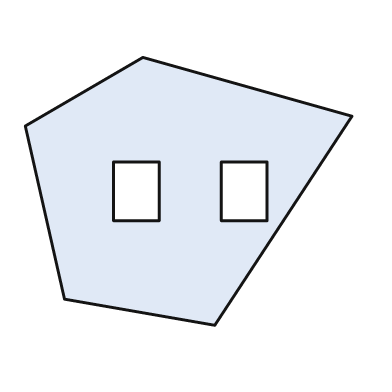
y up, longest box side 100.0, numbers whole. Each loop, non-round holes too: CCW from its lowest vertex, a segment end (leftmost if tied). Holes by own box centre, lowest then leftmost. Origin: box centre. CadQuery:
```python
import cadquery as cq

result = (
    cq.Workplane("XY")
    .moveTo(8.0, -41.0)
    .lineTo(50.0, 23.0)
    .lineTo(-14.0, 41.0)
    .lineTo(-50.0, 20.0)
    .lineTo(-38.0, -33.0)
    .close()
    .moveTo(-23.0, -9.0)
    .lineTo(-9.0, -9.0)
    .lineTo(-9.0, 9.0)
    .lineTo(-23.0, 9.0)
    .close()
    .moveTo(10.0, -9.0)
    .lineTo(24.0, -9.0)
    .lineTo(24.0, 9.0)
    .lineTo(10.0, 9.0)
    .close()
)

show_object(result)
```